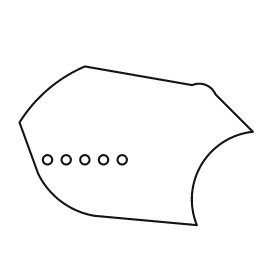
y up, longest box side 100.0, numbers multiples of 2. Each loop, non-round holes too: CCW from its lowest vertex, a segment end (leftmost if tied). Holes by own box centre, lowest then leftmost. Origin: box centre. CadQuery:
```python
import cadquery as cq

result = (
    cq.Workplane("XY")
    .moveTo(26.0, -34.0)
    .threePointArc((28.0, -8.0), (50.0, 6.0))
    .lineTo(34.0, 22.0)
    .threePointArc((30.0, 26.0), (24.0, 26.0))
    .lineTo(-22.0, 34.0)
    .threePointArc((-38.0, 24.0), (-50.0, 10.0))
    .lineTo(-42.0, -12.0)
    .threePointArc((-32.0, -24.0), (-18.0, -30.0))
    .close()
    .moveTo(-38.0, -6.0)
    .circle(2.0)
    .moveTo(-30.0, -6.0)
    .circle(2.0)
    .moveTo(-22.0, -6.0)
    .circle(2.0)
    .moveTo(-14.0, -6.0)
    .circle(2.0)
    .moveTo(-6.0, -6.0)
    .circle(2.0)
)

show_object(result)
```